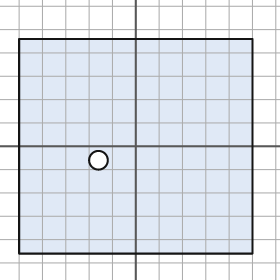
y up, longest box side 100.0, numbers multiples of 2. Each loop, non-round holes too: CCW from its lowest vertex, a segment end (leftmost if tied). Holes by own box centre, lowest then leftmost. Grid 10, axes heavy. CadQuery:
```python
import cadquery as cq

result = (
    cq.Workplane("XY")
    .moveTo(-50.0, -46.0)
    .lineTo(50.0, -46.0)
    .lineTo(50.0, 46.0)
    .lineTo(-50.0, 46.0)
    .close()
    .moveTo(-16.0, -6.0)
    .circle(4.0)
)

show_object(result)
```